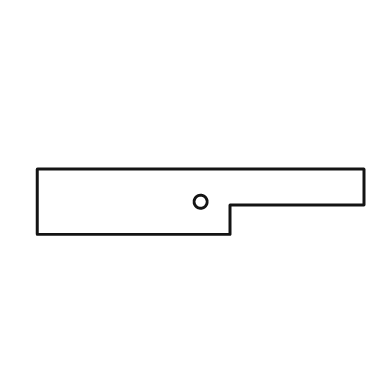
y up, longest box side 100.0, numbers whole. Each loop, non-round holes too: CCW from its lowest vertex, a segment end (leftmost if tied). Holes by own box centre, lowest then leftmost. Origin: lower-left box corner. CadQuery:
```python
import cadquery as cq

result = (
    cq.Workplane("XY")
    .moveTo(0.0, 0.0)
    .lineTo(59.0, 0.0)
    .lineTo(59.0, 9.0)
    .lineTo(100.0, 9.0)
    .lineTo(100.0, 20.0)
    .lineTo(0.0, 20.0)
    .close()
    .moveTo(50.0, 10.0)
    .circle(2.0)
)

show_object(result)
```